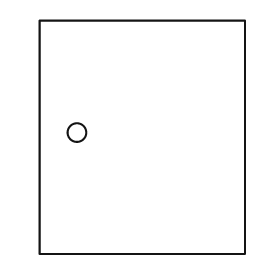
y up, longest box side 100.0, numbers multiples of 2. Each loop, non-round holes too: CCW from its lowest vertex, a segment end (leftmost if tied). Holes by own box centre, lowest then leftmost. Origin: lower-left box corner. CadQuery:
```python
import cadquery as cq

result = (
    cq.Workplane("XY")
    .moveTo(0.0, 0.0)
    .lineTo(88.0, 0.0)
    .lineTo(88.0, 100.0)
    .lineTo(0.0, 100.0)
    .close()
    .moveTo(16.0, 52.0)
    .circle(4.0)
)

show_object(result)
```